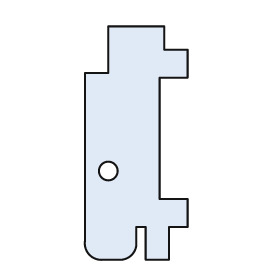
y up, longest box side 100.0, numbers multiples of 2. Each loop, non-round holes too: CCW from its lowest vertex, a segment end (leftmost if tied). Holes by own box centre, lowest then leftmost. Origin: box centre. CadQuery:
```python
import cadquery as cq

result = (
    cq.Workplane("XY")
    .moveTo(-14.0, -50.0)
    .lineTo(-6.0, -50.0)
    .threePointArc((-2.0, -48.0), (0.0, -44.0))
    .lineTo(0.0, -36.0)
    .lineTo(4.0, -36.0)
    .lineTo(4.0, -50.0)
    .lineTo(14.0, -50.0)
    .lineTo(14.0, -36.0)
    .lineTo(22.0, -36.0)
    .lineTo(22.0, -24.0)
    .lineTo(10.0, -24.0)
    .lineTo(10.0, 28.0)
    .lineTo(22.0, 28.0)
    .lineTo(22.0, 40.0)
    .lineTo(12.0, 40.0)
    .lineTo(12.0, 50.0)
    .lineTo(-12.0, 50.0)
    .lineTo(-12.0, 30.0)
    .lineTo(-22.0, 30.0)
    .lineTo(-22.0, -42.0)
    .threePointArc((-20.0, -48.0), (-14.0, -50.0))
    .close()
    .moveTo(-12.0, -12.0)
    .circle(4.0)
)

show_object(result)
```